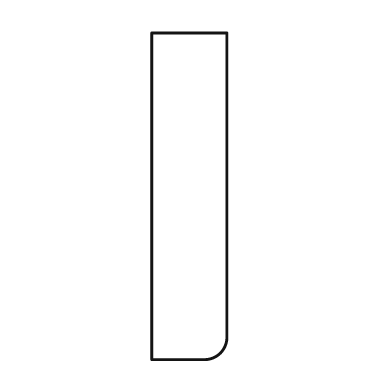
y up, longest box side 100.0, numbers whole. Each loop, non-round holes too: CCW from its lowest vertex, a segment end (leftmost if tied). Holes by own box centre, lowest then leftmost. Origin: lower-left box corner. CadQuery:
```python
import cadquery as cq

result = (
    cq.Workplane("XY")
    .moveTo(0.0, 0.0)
    .lineTo(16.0, 0.0)
    .threePointArc((21.0, 2.0), (23.0, 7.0))
    .lineTo(23.0, 100.0)
    .lineTo(0.0, 100.0)
    .close()
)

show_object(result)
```